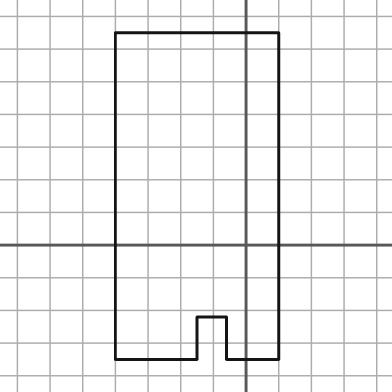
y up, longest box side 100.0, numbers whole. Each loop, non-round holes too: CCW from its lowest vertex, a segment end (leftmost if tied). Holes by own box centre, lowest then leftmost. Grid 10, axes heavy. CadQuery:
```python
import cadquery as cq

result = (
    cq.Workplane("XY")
    .moveTo(-40.0, -35.0)
    .lineTo(-15.0, -35.0)
    .lineTo(-15.0, -22.0)
    .lineTo(-6.0, -22.0)
    .lineTo(-6.0, -35.0)
    .lineTo(10.0, -35.0)
    .lineTo(10.0, 65.0)
    .lineTo(-40.0, 65.0)
    .close()
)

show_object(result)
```